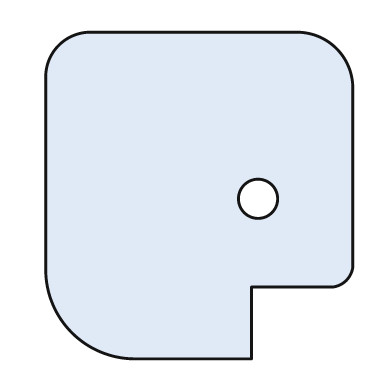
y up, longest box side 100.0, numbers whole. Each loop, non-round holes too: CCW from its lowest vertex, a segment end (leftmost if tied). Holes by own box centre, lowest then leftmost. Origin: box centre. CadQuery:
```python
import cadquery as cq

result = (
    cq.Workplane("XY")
    .moveTo(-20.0, -50.0)
    .lineTo(16.0, -50.0)
    .lineTo(16.0, -28.0)
    .lineTo(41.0, -28.0)
    .threePointArc((45.0, -26.0), (47.0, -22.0))
    .lineTo(47.0, 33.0)
    .threePointArc((42.0, 45.0), (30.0, 50.0))
    .lineTo(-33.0, 50.0)
    .threePointArc((-43.0, 46.0), (-47.0, 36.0))
    .lineTo(-47.0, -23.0)
    .threePointArc((-39.0, -42.0), (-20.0, -50.0))
    .close()
    .moveTo(18.0, -1.0)
    .circle(6.0)
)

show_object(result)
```